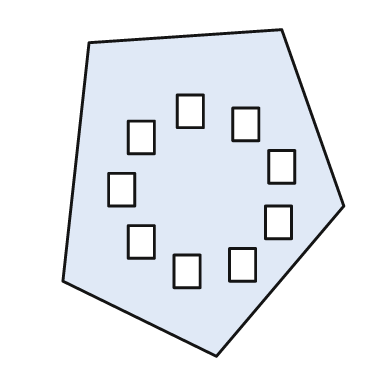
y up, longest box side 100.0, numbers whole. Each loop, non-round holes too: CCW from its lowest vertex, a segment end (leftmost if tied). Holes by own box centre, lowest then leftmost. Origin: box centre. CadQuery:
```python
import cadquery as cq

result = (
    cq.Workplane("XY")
    .moveTo(4.0, -50.0)
    .lineTo(43.0, -4.0)
    .lineTo(24.0, 50.0)
    .lineTo(-35.0, 46.0)
    .lineTo(-43.0, -27.0)
    .close()
    .moveTo(-9.0, -29.0)
    .lineTo(-1.0, -29.0)
    .lineTo(-1.0, -19.0)
    .lineTo(-9.0, -19.0)
    .close()
    .moveTo(8.0, -27.0)
    .lineTo(16.0, -27.0)
    .lineTo(16.0, -17.0)
    .lineTo(8.0, -17.0)
    .close()
    .moveTo(-23.0, -20.0)
    .lineTo(-15.0, -20.0)
    .lineTo(-15.0, -10.0)
    .lineTo(-23.0, -10.0)
    .close()
    .moveTo(19.0, -14.0)
    .lineTo(27.0, -14.0)
    .lineTo(27.0, -4.0)
    .lineTo(19.0, -4.0)
    .close()
    .moveTo(-29.0, -4.0)
    .lineTo(-21.0, -4.0)
    .lineTo(-21.0, 6.0)
    .lineTo(-29.0, 6.0)
    .close()
    .moveTo(20.0, 3.0)
    .lineTo(28.0, 3.0)
    .lineTo(28.0, 13.0)
    .lineTo(20.0, 13.0)
    .close()
    .moveTo(-23.0, 12.0)
    .lineTo(-15.0, 12.0)
    .lineTo(-15.0, 22.0)
    .lineTo(-23.0, 22.0)
    .close()
    .moveTo(9.0, 16.0)
    .lineTo(17.0, 16.0)
    .lineTo(17.0, 26.0)
    .lineTo(9.0, 26.0)
    .close()
    .moveTo(-8.0, 20.0)
    .lineTo(0.0, 20.0)
    .lineTo(0.0, 30.0)
    .lineTo(-8.0, 30.0)
    .close()
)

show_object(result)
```